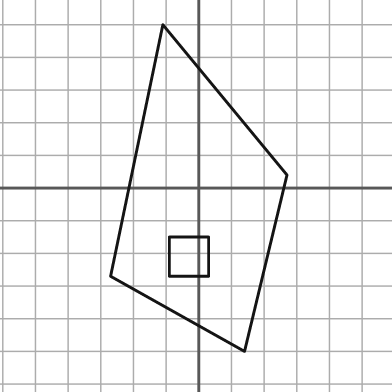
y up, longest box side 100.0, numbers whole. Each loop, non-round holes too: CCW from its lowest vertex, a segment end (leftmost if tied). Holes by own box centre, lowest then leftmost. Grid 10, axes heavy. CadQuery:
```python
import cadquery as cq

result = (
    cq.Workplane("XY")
    .moveTo(14.0, -50.0)
    .lineTo(27.0, 4.0)
    .lineTo(-11.0, 50.0)
    .lineTo(-27.0, -27.0)
    .close()
    .moveTo(-9.0, -27.0)
    .lineTo(3.0, -27.0)
    .lineTo(3.0, -15.0)
    .lineTo(-9.0, -15.0)
    .close()
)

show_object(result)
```